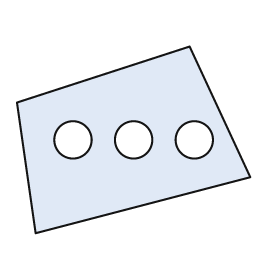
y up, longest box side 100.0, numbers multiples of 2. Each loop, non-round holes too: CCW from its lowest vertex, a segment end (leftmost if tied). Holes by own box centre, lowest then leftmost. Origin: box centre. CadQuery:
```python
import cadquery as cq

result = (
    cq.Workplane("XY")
    .moveTo(-42.0, -40.0)
    .lineTo(50.0, -16.0)
    .lineTo(24.0, 40.0)
    .lineTo(-50.0, 16.0)
    .close()
    .moveTo(-26.0, 0.0)
    .circle(8.0)
    .moveTo(0.0, 0.0)
    .circle(8.0)
    .moveTo(26.0, 0.0)
    .circle(8.0)
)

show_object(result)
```